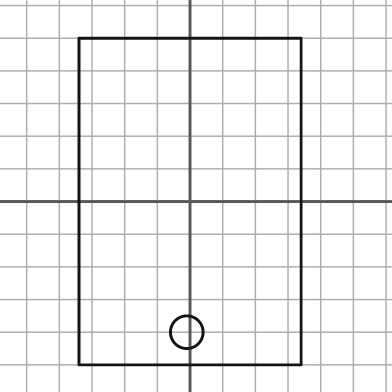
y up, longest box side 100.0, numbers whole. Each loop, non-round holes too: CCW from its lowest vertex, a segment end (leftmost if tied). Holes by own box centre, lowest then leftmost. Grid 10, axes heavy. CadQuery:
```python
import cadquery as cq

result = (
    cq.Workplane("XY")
    .moveTo(-34.0, -50.0)
    .lineTo(34.0, -50.0)
    .lineTo(34.0, 50.0)
    .lineTo(-34.0, 50.0)
    .close()
    .moveTo(-1.0, -40.0)
    .circle(5.0)
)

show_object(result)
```